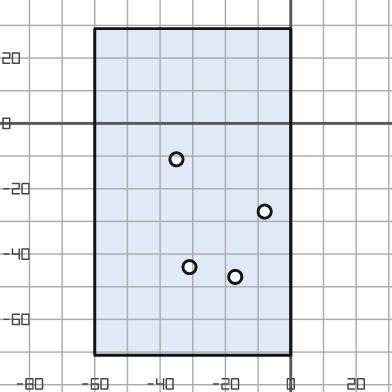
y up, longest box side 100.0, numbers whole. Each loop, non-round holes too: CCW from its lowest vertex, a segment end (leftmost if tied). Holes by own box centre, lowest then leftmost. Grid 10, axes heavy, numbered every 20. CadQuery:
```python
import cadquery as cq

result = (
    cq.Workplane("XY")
    .moveTo(-60.0, -71.0)
    .lineTo(0.0, -71.0)
    .lineTo(0.0, 29.0)
    .lineTo(-60.0, 29.0)
    .close()
    .moveTo(-17.0, -47.0)
    .circle(2.0)
    .moveTo(-31.0, -44.0)
    .circle(2.0)
    .moveTo(-8.0, -27.0)
    .circle(2.0)
    .moveTo(-35.0, -11.0)
    .circle(2.0)
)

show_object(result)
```